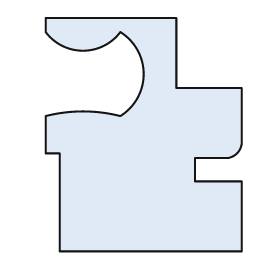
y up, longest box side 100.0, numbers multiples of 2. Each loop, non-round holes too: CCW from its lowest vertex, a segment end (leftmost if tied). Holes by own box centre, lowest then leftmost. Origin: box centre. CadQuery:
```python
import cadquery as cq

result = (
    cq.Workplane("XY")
    .moveTo(-36.0, -50.0)
    .lineTo(42.0, -50.0)
    .lineTo(42.0, -20.0)
    .lineTo(22.0, -20.0)
    .lineTo(22.0, -10.0)
    .lineTo(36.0, -10.0)
    .threePointArc((40.0, -8.0), (42.0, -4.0))
    .lineTo(42.0, 20.0)
    .lineTo(14.0, 20.0)
    .lineTo(14.0, 50.0)
    .lineTo(-42.0, 50.0)
    .lineTo(-42.0, 44.0)
    .threePointArc((-26.0, 36.0), (-10.0, 44.0))
    .threePointArc((0.0, 26.0), (-10.0, 8.0))
    .threePointArc((-26.0, 10.0), (-42.0, 8.0))
    .lineTo(-42.0, -8.0)
    .lineTo(-36.0, -8.0)
    .close()
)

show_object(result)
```